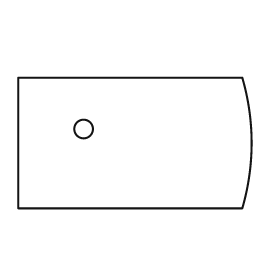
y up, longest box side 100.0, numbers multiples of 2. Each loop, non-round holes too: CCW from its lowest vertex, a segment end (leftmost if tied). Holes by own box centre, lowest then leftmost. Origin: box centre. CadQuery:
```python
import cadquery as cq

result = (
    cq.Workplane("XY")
    .moveTo(-50.0, -28.0)
    .lineTo(46.0, -28.0)
    .threePointArc((50.0, 0.0), (46.0, 28.0))
    .lineTo(-50.0, 28.0)
    .close()
    .moveTo(-22.0, 6.0)
    .circle(4.0)
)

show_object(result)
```